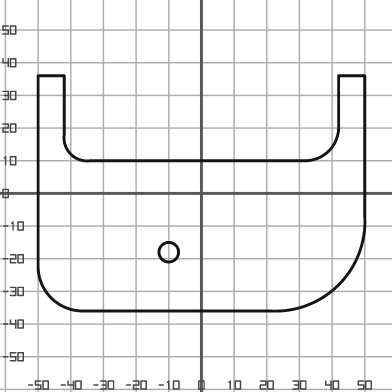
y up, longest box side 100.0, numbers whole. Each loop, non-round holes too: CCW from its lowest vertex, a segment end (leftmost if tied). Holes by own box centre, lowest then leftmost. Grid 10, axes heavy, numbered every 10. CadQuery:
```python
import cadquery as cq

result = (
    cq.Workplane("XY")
    .moveTo(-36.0, -36.0)
    .lineTo(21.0, -36.0)
    .threePointArc((42.0, -28.0), (50.0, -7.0))
    .lineTo(50.0, 36.0)
    .lineTo(42.0, 36.0)
    .lineTo(42.0, 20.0)
    .threePointArc((39.0, 13.0), (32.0, 10.0))
    .lineTo(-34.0, 10.0)
    .threePointArc((-40.0, 12.0), (-42.0, 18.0))
    .lineTo(-42.0, 36.0)
    .lineTo(-50.0, 36.0)
    .lineTo(-50.0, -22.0)
    .threePointArc((-46.0, -32.0), (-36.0, -36.0))
    .close()
    .moveTo(-10.0, -18.0)
    .circle(3.0)
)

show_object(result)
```